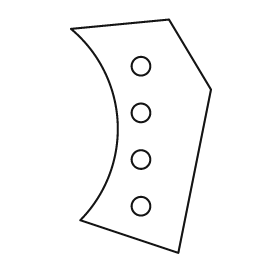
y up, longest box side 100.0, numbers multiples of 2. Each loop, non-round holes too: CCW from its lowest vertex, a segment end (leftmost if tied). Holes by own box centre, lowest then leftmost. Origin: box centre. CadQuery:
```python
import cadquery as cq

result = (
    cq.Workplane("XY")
    .moveTo(16.0, -50.0)
    .lineTo(30.0, 20.0)
    .lineTo(12.0, 50.0)
    .lineTo(-30.0, 46.0)
    .threePointArc((-10.0, 6.0), (-26.0, -36.0))
    .close()
    .moveTo(0.0, -30.0)
    .circle(4.0)
    .moveTo(0.0, -10.0)
    .circle(4.0)
    .moveTo(0.0, 10.0)
    .circle(4.0)
    .moveTo(0.0, 30.0)
    .circle(4.0)
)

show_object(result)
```